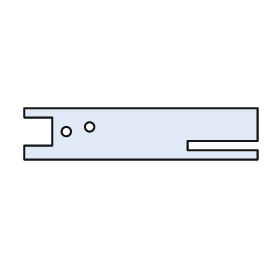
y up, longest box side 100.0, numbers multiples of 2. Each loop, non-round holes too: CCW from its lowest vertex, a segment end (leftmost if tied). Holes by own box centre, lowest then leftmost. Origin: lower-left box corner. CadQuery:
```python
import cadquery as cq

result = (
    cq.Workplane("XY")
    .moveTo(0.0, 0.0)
    .lineTo(100.0, 0.0)
    .lineTo(100.0, 4.0)
    .lineTo(70.0, 4.0)
    .lineTo(70.0, 8.0)
    .lineTo(100.0, 8.0)
    .lineTo(100.0, 22.0)
    .lineTo(0.0, 22.0)
    .lineTo(0.0, 18.0)
    .lineTo(12.0, 18.0)
    .lineTo(12.0, 6.0)
    .lineTo(0.0, 6.0)
    .close()
    .moveTo(18.0, 12.0)
    .circle(2.0)
    .moveTo(28.0, 14.0)
    .circle(2.0)
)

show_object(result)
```